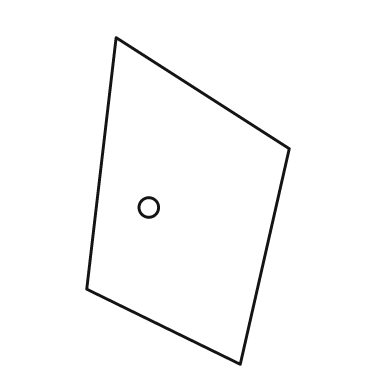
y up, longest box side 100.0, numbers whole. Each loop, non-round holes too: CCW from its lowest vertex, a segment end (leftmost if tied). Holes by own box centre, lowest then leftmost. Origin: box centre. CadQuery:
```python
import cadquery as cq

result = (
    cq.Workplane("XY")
    .moveTo(16.0, -50.0)
    .lineTo(31.0, 16.0)
    .lineTo(-22.0, 50.0)
    .lineTo(-31.0, -27.0)
    .close()
    .moveTo(-12.0, -2.0)
    .circle(3.0)
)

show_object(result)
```